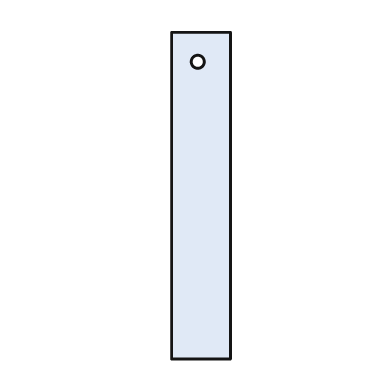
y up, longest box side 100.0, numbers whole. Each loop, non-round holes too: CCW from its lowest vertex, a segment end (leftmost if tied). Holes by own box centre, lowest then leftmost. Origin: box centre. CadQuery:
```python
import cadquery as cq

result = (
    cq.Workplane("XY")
    .moveTo(-9.0, -50.0)
    .lineTo(9.0, -50.0)
    .lineTo(9.0, 50.0)
    .lineTo(-9.0, 50.0)
    .close()
    .moveTo(-1.0, 41.0)
    .circle(2.0)
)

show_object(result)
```